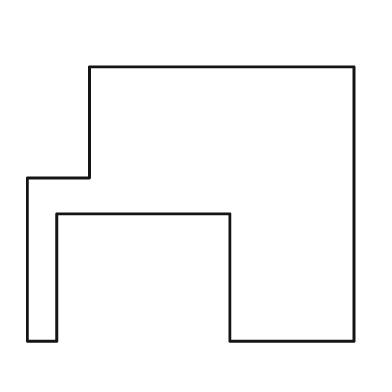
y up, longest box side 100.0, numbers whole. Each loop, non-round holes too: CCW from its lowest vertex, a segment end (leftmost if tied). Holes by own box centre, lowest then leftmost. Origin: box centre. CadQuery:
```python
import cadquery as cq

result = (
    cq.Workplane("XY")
    .moveTo(-50.0, -42.0)
    .lineTo(-41.0, -42.0)
    .lineTo(-41.0, -3.0)
    .lineTo(12.0, -3.0)
    .lineTo(12.0, -42.0)
    .lineTo(50.0, -42.0)
    .lineTo(50.0, 42.0)
    .lineTo(-31.0, 42.0)
    .lineTo(-31.0, 8.0)
    .lineTo(-50.0, 8.0)
    .close()
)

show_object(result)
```